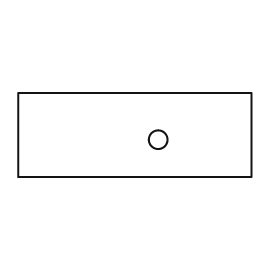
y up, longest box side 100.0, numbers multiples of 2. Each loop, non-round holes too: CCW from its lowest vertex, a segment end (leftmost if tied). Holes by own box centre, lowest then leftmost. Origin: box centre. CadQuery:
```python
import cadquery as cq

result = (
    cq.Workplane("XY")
    .moveTo(-50.0, -18.0)
    .lineTo(50.0, -18.0)
    .lineTo(50.0, 18.0)
    .lineTo(-50.0, 18.0)
    .close()
    .moveTo(10.0, -2.0)
    .circle(4.0)
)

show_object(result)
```